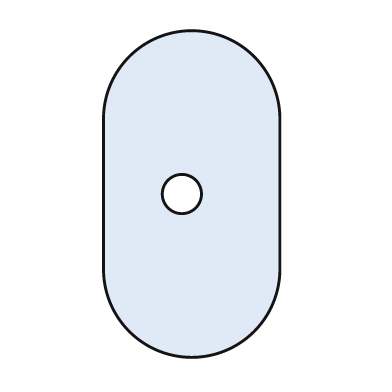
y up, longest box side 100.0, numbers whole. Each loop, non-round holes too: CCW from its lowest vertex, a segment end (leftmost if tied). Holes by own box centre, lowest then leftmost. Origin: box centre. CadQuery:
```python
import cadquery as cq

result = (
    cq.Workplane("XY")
    .moveTo(-27.0, -23.0)
    .threePointArc((0.0, -50.0), (27.0, -23.0))
    .lineTo(27.0, 23.0)
    .threePointArc((0.0, 50.0), (-27.0, 23.0))
    .close()
    .moveTo(-3.0, 0.0)
    .circle(6.0)
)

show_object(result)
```